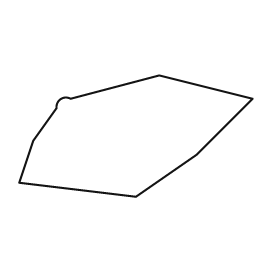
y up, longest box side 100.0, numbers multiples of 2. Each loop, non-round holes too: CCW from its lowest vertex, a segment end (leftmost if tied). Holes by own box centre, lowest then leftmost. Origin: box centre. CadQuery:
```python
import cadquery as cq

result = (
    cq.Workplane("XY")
    .moveTo(0.0, -26.0)
    .lineTo(26.0, -8.0)
    .lineTo(50.0, 16.0)
    .lineTo(10.0, 26.0)
    .lineTo(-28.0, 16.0)
    .threePointArc((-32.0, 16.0), (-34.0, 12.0))
    .lineTo(-44.0, -2.0)
    .lineTo(-50.0, -20.0)
    .close()
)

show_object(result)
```